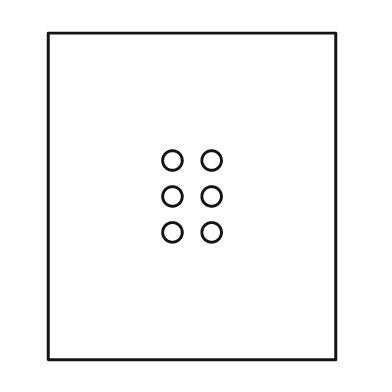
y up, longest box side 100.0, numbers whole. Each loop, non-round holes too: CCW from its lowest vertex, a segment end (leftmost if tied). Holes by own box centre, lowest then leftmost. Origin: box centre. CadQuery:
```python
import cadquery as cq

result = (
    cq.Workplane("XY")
    .moveTo(-44.0, -50.0)
    .lineTo(44.0, -50.0)
    .lineTo(44.0, 50.0)
    .lineTo(-44.0, 50.0)
    .close()
    .moveTo(-6.0, -11.0)
    .circle(3.0)
    .moveTo(6.0, -11.0)
    .circle(3.0)
    .moveTo(-6.0, 0.0)
    .circle(3.0)
    .moveTo(6.0, 0.0)
    .circle(3.0)
    .moveTo(-6.0, 11.0)
    .circle(3.0)
    .moveTo(6.0, 11.0)
    .circle(3.0)
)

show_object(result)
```